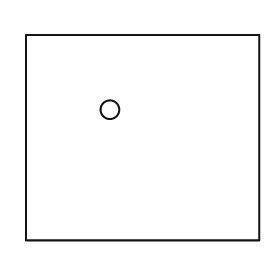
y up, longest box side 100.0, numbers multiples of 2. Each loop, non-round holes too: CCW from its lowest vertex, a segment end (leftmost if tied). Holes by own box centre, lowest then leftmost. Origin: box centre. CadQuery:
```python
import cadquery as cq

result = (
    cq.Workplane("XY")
    .moveTo(-50.0, -44.0)
    .lineTo(50.0, -44.0)
    .lineTo(50.0, 44.0)
    .lineTo(-50.0, 44.0)
    .close()
    .moveTo(-14.0, 12.0)
    .circle(4.0)
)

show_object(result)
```